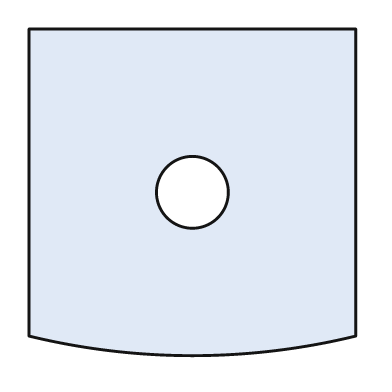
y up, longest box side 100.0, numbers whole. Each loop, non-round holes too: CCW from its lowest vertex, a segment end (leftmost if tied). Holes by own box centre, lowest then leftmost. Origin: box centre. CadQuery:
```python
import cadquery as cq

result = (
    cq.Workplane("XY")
    .moveTo(-50.0, -44.0)
    .threePointArc((0.0, -50.0), (50.0, -44.0))
    .lineTo(50.0, 50.0)
    .lineTo(-50.0, 50.0)
    .close()
    .moveTo(0.0, 0.0)
    .circle(11.0)
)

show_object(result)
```